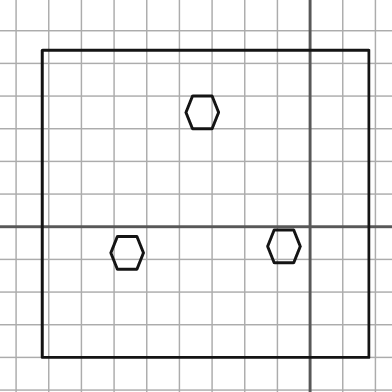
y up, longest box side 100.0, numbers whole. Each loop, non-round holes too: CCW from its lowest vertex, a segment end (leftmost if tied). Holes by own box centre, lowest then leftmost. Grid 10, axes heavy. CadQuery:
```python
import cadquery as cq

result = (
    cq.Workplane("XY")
    .moveTo(-82.0, -40.0)
    .lineTo(18.0, -40.0)
    .lineTo(18.0, 54.0)
    .lineTo(-82.0, 54.0)
    .close()
    .moveTo(-59.0, -13.0)
    .lineTo(-53.0, -13.0)
    .lineTo(-51.0, -8.0)
    .lineTo(-53.0, -3.0)
    .lineTo(-59.0, -3.0)
    .lineTo(-61.0, -8.0)
    .close()
    .moveTo(-11.0, -11.0)
    .lineTo(-5.0, -11.0)
    .lineTo(-3.0, -6.0)
    .lineTo(-5.0, -1.0)
    .lineTo(-11.0, -1.0)
    .lineTo(-13.0, -6.0)
    .close()
    .moveTo(-36.0, 30.0)
    .lineTo(-30.0, 30.0)
    .lineTo(-28.0, 35.0)
    .lineTo(-30.0, 40.0)
    .lineTo(-36.0, 40.0)
    .lineTo(-38.0, 35.0)
    .close()
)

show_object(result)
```